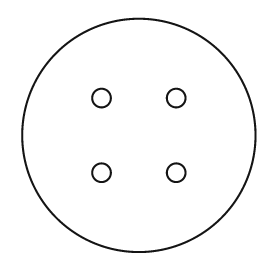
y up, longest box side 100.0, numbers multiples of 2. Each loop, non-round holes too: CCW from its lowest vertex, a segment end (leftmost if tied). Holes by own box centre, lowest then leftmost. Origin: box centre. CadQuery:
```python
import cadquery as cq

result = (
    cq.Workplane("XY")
    .moveTo(0.0, 0.0)
    .circle(50.0)
    .moveTo(-16.0, -16.0)
    .circle(4.0)
    .moveTo(16.0, -16.0)
    .circle(4.0)
    .moveTo(-16.0, 16.0)
    .circle(4.0)
    .moveTo(16.0, 16.0)
    .circle(4.0)
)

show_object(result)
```